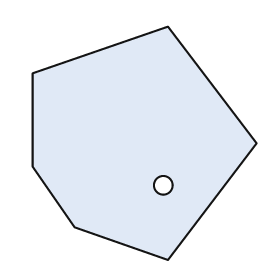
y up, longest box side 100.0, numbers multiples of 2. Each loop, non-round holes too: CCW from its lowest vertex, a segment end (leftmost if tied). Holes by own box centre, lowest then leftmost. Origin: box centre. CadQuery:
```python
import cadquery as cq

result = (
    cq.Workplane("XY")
    .moveTo(10.0, -50.0)
    .lineTo(48.0, 0.0)
    .lineTo(10.0, 50.0)
    .lineTo(-48.0, 30.0)
    .lineTo(-48.0, -10.0)
    .lineTo(-30.0, -36.0)
    .close()
    .moveTo(8.0, -18.0)
    .circle(4.0)
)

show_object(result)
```